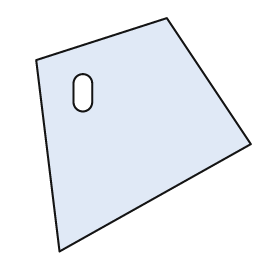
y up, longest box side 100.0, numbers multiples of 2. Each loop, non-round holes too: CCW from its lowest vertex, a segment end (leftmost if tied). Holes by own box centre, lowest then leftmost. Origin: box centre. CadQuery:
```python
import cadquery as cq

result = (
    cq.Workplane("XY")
    .moveTo(-36.0, -50.0)
    .lineTo(46.0, -4.0)
    .lineTo(10.0, 50.0)
    .lineTo(-46.0, 32.0)
    .close()
    .moveTo(-30.0, 14.0)
    .threePointArc((-26.0, 10.0), (-22.0, 14.0))
    .lineTo(-22.0, 22.0)
    .threePointArc((-26.0, 26.0), (-30.0, 22.0))
    .close()
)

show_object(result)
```